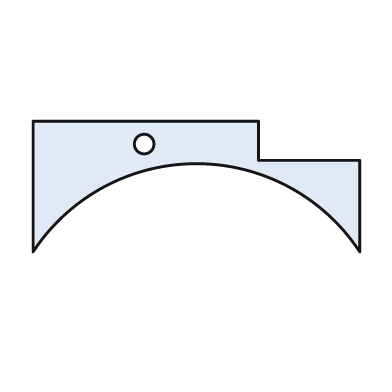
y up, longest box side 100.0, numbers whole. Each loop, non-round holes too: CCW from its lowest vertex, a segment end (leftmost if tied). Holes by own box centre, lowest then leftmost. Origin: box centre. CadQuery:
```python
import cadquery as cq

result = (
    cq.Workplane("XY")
    .moveTo(-50.0, -20.0)
    .threePointArc((0.0, 7.0), (50.0, -20.0))
    .lineTo(50.0, 8.0)
    .lineTo(19.0, 8.0)
    .lineTo(19.0, 20.0)
    .lineTo(-50.0, 20.0)
    .close()
    .moveTo(-16.0, 13.0)
    .circle(3.0)
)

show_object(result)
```